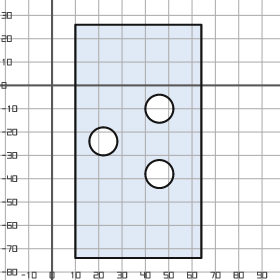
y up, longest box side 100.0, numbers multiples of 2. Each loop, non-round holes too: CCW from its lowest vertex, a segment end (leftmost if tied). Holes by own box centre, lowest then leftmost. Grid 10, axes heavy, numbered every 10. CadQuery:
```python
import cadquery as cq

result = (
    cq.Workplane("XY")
    .moveTo(10.0, -74.0)
    .lineTo(64.0, -74.0)
    .lineTo(64.0, 26.0)
    .lineTo(10.0, 26.0)
    .close()
    .moveTo(46.0, -38.0)
    .circle(6.0)
    .moveTo(22.0, -24.0)
    .circle(6.0)
    .moveTo(46.0, -10.0)
    .circle(6.0)
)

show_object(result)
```